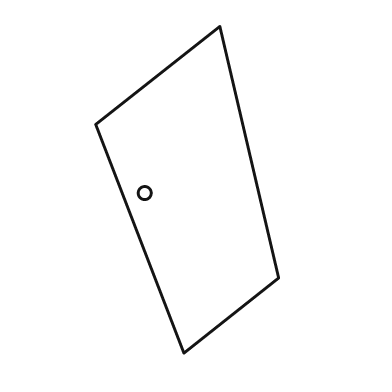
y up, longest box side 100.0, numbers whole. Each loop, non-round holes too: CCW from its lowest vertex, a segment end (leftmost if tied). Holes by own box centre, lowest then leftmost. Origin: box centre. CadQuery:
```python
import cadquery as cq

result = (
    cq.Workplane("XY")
    .moveTo(-1.0, -50.0)
    .lineTo(28.0, -27.0)
    .lineTo(10.0, 50.0)
    .lineTo(-28.0, 20.0)
    .close()
    .moveTo(-13.0, -1.0)
    .circle(2.0)
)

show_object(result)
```